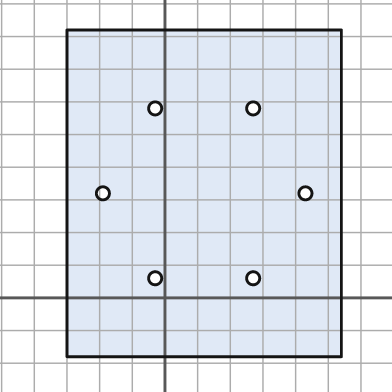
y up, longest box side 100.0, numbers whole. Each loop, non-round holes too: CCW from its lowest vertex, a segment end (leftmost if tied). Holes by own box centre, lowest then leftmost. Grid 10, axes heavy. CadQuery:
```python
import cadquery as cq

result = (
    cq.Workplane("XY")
    .moveTo(-30.0, -18.0)
    .lineTo(54.0, -18.0)
    .lineTo(54.0, 82.0)
    .lineTo(-30.0, 82.0)
    .close()
    .moveTo(-3.0, 6.0)
    .circle(2.0)
    .moveTo(27.0, 6.0)
    .circle(2.0)
    .moveTo(-19.0, 32.0)
    .circle(2.0)
    .moveTo(43.0, 32.0)
    .circle(2.0)
    .moveTo(-3.0, 58.0)
    .circle(2.0)
    .moveTo(27.0, 58.0)
    .circle(2.0)
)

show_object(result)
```